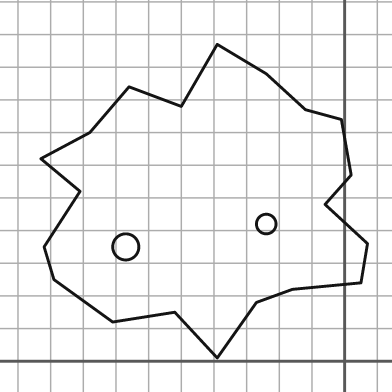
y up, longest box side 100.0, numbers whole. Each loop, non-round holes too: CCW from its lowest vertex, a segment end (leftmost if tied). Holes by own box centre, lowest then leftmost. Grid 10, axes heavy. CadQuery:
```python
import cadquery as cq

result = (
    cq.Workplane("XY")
    .moveTo(-39.0, 1.0)
    .lineTo(-27.0, 18.0)
    .lineTo(-16.0, 22.0)
    .lineTo(5.0, 24.0)
    .lineTo(7.0, 36.0)
    .lineTo(-6.0, 48.0)
    .lineTo(2.0, 57.0)
    .lineTo(-1.0, 74.0)
    .lineTo(-12.0, 77.0)
    .lineTo(-24.0, 88.0)
    .lineTo(-39.0, 97.0)
    .lineTo(-50.0, 78.0)
    .lineTo(-66.0, 84.0)
    .lineTo(-78.0, 70.0)
    .lineTo(-93.0, 62.0)
    .lineTo(-81.0, 52.0)
    .lineTo(-92.0, 35.0)
    .lineTo(-89.0, 25.0)
    .lineTo(-71.0, 12.0)
    .lineTo(-52.0, 15.0)
    .close()
    .moveTo(-67.0, 35.0)
    .circle(4.0)
    .moveTo(-24.0, 42.0)
    .circle(3.0)
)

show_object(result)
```